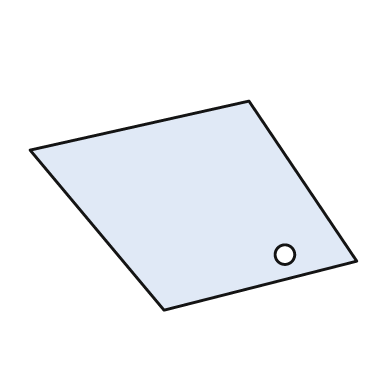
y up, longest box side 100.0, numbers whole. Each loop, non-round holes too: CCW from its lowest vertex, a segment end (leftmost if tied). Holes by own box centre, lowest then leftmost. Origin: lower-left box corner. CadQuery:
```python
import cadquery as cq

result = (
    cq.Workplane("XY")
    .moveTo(41.0, 0.0)
    .lineTo(100.0, 15.0)
    .lineTo(67.0, 64.0)
    .lineTo(0.0, 49.0)
    .close()
    .moveTo(78.0, 17.0)
    .circle(3.0)
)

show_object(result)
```